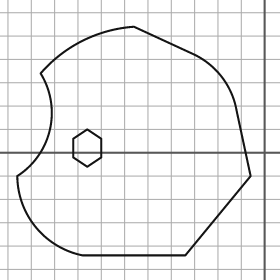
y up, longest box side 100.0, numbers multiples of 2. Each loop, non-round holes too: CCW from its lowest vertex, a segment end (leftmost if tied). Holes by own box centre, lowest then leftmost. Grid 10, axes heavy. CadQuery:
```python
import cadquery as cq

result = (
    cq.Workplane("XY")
    .moveTo(-78.0, -44.0)
    .lineTo(-34.0, -44.0)
    .lineTo(-6.0, -10.0)
    .lineTo(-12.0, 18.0)
    .threePointArc((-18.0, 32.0), (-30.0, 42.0))
    .lineTo(-56.0, 54.0)
    .threePointArc((-78.0, 48.0), (-96.0, 34.0))
    .threePointArc((-92.0, 10.0), (-106.0, -10.0))
    .threePointArc((-98.0, -32.0), (-78.0, -44.0))
    .close()
    .moveTo(-76.0, -6.0)
    .lineTo(-70.0, -2.0)
    .lineTo(-70.0, 6.0)
    .lineTo(-76.0, 10.0)
    .lineTo(-82.0, 6.0)
    .lineTo(-82.0, -2.0)
    .close()
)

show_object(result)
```